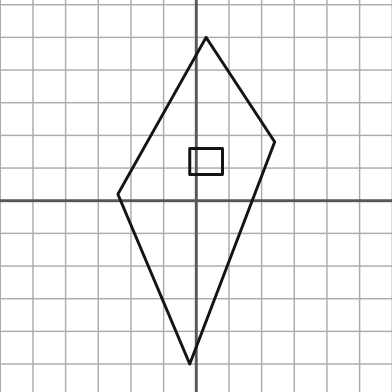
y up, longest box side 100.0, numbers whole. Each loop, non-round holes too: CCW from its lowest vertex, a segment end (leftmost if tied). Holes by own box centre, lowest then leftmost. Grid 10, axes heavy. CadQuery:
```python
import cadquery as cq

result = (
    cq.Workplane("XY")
    .moveTo(-2.0, -50.0)
    .lineTo(24.0, 18.0)
    .lineTo(3.0, 50.0)
    .lineTo(-24.0, 2.0)
    .close()
    .moveTo(-2.0, 8.0)
    .lineTo(8.0, 8.0)
    .lineTo(8.0, 16.0)
    .lineTo(-2.0, 16.0)
    .close()
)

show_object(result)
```